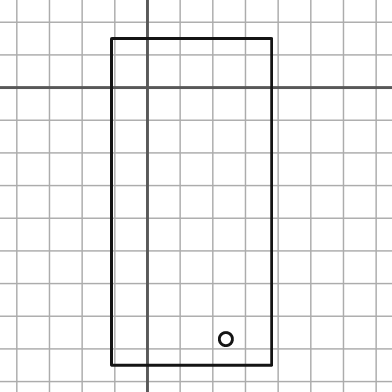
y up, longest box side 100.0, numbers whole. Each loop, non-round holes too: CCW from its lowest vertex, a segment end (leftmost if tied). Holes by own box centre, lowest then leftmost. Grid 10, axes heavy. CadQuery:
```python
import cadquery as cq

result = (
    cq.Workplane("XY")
    .moveTo(-11.0, -85.0)
    .lineTo(38.0, -85.0)
    .lineTo(38.0, 15.0)
    .lineTo(-11.0, 15.0)
    .close()
    .moveTo(24.0, -77.0)
    .circle(2.0)
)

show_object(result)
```